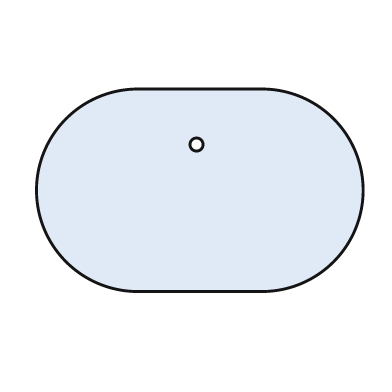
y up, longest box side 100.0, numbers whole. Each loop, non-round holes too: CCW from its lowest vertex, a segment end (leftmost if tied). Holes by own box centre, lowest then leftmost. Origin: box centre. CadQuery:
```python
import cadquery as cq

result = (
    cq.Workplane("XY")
    .moveTo(-19.0, -31.0)
    .lineTo(19.0, -31.0)
    .threePointArc((50.0, 0.0), (19.0, 31.0))
    .lineTo(-19.0, 31.0)
    .threePointArc((-50.0, 0.0), (-19.0, -31.0))
    .close()
    .moveTo(-1.0, 14.0)
    .circle(2.0)
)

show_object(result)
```